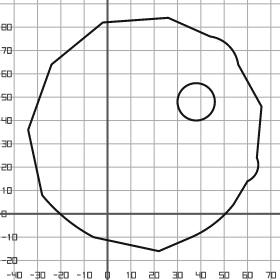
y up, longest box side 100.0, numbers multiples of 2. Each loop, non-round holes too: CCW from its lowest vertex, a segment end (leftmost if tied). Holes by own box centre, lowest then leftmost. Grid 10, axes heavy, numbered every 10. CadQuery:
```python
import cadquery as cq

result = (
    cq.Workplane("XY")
    .moveTo(22.0, -16.0)
    .lineTo(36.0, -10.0)
    .threePointArc((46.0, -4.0), (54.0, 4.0))
    .lineTo(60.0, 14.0)
    .threePointArc((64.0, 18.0), (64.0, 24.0))
    .lineTo(66.0, 46.0)
    .lineTo(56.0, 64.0)
    .threePointArc((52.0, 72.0), (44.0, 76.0))
    .lineTo(26.0, 84.0)
    .lineTo(-2.0, 82.0)
    .lineTo(-24.0, 64.0)
    .lineTo(-34.0, 36.0)
    .lineTo(-28.0, 8.0)
    .threePointArc((-18.0, -2.0), (-6.0, -10.0))
    .close()
    .moveTo(38.0, 48.0)
    .circle(8.0)
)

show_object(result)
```